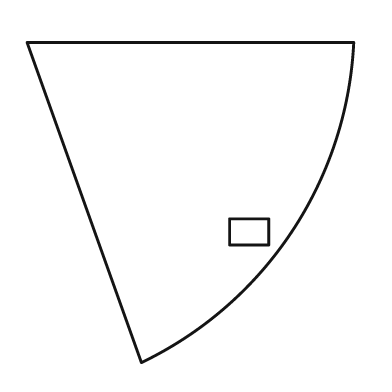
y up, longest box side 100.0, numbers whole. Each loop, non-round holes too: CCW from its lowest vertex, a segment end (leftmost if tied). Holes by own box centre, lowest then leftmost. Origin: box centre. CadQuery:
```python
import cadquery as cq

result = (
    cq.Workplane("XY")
    .moveTo(-15.0, -49.0)
    .threePointArc((31.0, -9.0), (50.0, 49.0))
    .lineTo(-50.0, 49.0)
    .close()
    .moveTo(12.0, -13.0)
    .lineTo(24.0, -13.0)
    .lineTo(24.0, -5.0)
    .lineTo(12.0, -5.0)
    .close()
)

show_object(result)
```